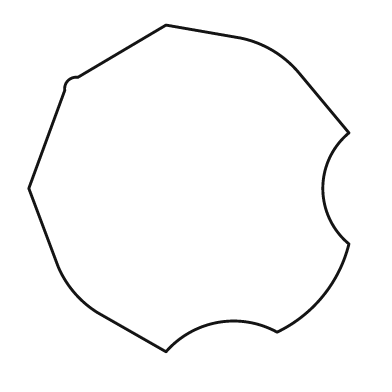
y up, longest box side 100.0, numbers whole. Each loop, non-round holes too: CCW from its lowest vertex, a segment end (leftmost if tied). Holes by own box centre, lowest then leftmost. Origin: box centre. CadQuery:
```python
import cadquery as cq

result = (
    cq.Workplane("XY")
    .moveTo(-7.0, -50.0)
    .threePointArc((9.0, -41.0), (27.0, -44.0))
    .threePointArc((41.0, -33.0), (49.0, -17.0))
    .threePointArc((41.0, 0.0), (49.0, 17.0))
    .lineTo(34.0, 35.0)
    .threePointArc((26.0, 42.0), (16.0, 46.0))
    .lineTo(-7.0, 50.0)
    .lineTo(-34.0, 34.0)
    .threePointArc((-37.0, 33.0), (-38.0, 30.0))
    .lineTo(-49.0, 0.0)
    .lineTo(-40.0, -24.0)
    .threePointArc((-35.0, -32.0), (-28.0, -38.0))
    .close()
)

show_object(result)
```